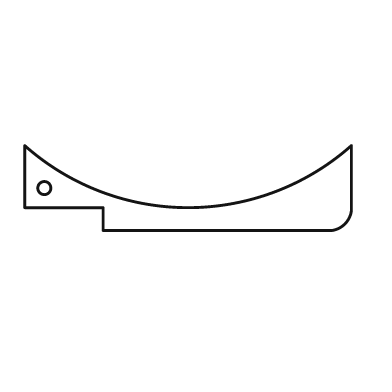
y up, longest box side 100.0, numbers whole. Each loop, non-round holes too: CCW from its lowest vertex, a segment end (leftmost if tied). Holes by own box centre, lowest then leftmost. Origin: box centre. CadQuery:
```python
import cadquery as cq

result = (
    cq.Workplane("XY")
    .moveTo(-26.0, -13.0)
    .lineTo(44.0, -13.0)
    .threePointArc((48.0, -11.0), (50.0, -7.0))
    .lineTo(50.0, 13.0)
    .threePointArc((0.0, -6.0), (-50.0, 13.0))
    .lineTo(-50.0, -6.0)
    .lineTo(-26.0, -6.0)
    .close()
    .moveTo(-44.0, 0.0)
    .circle(2.0)
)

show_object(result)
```